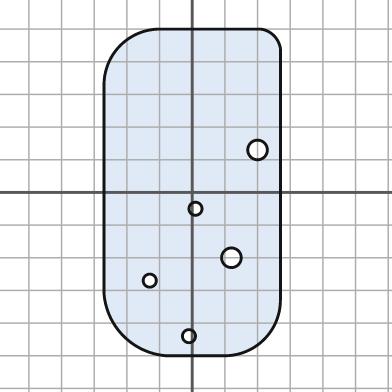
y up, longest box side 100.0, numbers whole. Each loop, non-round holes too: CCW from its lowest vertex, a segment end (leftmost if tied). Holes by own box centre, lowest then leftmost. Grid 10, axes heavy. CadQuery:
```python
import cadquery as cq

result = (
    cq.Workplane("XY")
    .moveTo(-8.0, -50.0)
    .lineTo(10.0, -50.0)
    .threePointArc((22.0, -45.0), (27.0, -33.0))
    .lineTo(27.0, 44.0)
    .threePointArc((25.0, 48.0), (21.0, 50.0))
    .lineTo(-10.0, 50.0)
    .threePointArc((-22.0, 45.0), (-27.0, 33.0))
    .lineTo(-27.0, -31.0)
    .threePointArc((-21.0, -44.0), (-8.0, -50.0))
    .close()
    .moveTo(-1.0, -44.0)
    .circle(2.0)
    .moveTo(-13.0, -27.0)
    .circle(2.0)
    .moveTo(12.0, -20.0)
    .circle(3.0)
    .moveTo(1.0, -5.0)
    .circle(2.0)
    .moveTo(20.0, 13.0)
    .circle(3.0)
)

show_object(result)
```